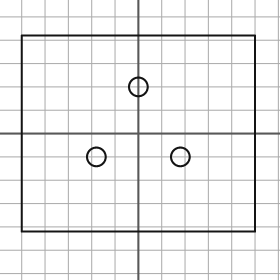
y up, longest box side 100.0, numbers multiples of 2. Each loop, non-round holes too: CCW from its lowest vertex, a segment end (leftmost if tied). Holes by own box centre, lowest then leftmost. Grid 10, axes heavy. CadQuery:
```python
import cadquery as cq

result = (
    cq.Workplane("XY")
    .moveTo(-50.0, -42.0)
    .lineTo(50.0, -42.0)
    .lineTo(50.0, 42.0)
    .lineTo(-50.0, 42.0)
    .close()
    .moveTo(-18.0, -10.0)
    .circle(4.0)
    .moveTo(18.0, -10.0)
    .circle(4.0)
    .moveTo(0.0, 20.0)
    .circle(4.0)
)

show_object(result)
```